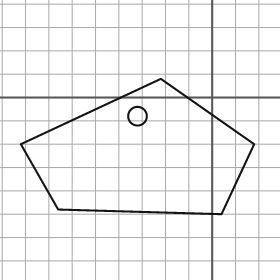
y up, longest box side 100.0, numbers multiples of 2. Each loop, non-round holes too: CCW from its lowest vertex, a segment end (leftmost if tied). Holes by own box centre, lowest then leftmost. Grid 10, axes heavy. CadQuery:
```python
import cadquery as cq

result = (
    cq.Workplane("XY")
    .moveTo(4.0, -50.0)
    .lineTo(18.0, -20.0)
    .lineTo(-22.0, 8.0)
    .lineTo(-82.0, -20.0)
    .lineTo(-66.0, -48.0)
    .close()
    .moveTo(-32.0, -8.0)
    .circle(4.0)
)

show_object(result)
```